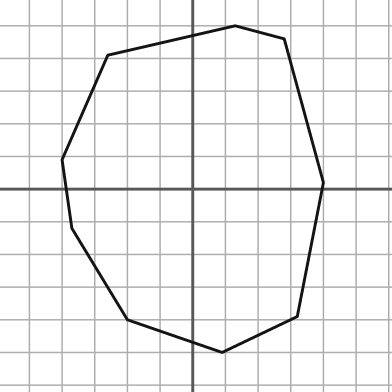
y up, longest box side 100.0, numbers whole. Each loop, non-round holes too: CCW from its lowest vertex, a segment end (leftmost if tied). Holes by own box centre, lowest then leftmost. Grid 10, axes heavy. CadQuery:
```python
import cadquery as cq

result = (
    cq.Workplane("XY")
    .moveTo(9.0, -50.0)
    .lineTo(32.0, -39.0)
    .lineTo(40.0, 2.0)
    .lineTo(28.0, 46.0)
    .lineTo(13.0, 50.0)
    .lineTo(-26.0, 41.0)
    .lineTo(-40.0, 9.0)
    .lineTo(-37.0, -12.0)
    .lineTo(-20.0, -40.0)
    .close()
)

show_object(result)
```